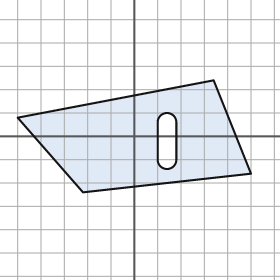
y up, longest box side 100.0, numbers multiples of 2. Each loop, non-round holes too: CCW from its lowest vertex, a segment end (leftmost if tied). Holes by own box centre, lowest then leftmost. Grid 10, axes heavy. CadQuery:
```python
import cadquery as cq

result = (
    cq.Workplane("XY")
    .moveTo(-22.0, -24.0)
    .lineTo(50.0, -16.0)
    .lineTo(34.0, 24.0)
    .lineTo(-50.0, 8.0)
    .close()
    .moveTo(10.0, -10.0)
    .threePointArc((14.0, -14.0), (18.0, -10.0))
    .lineTo(18.0, 6.0)
    .threePointArc((14.0, 10.0), (10.0, 6.0))
    .close()
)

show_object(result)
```